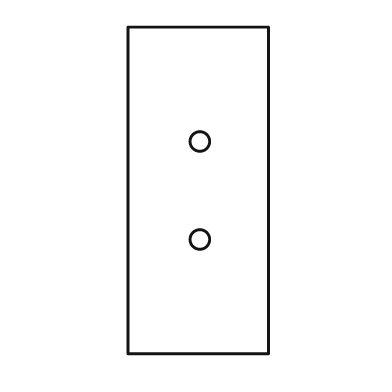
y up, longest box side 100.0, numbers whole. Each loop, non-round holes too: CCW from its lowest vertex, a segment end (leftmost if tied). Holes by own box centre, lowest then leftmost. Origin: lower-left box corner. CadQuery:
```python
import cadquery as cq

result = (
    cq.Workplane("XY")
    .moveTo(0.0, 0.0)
    .lineTo(43.0, 0.0)
    .lineTo(43.0, 100.0)
    .lineTo(0.0, 100.0)
    .close()
    .moveTo(22.0, 35.0)
    .circle(3.0)
    .moveTo(22.0, 65.0)
    .circle(3.0)
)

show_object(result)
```